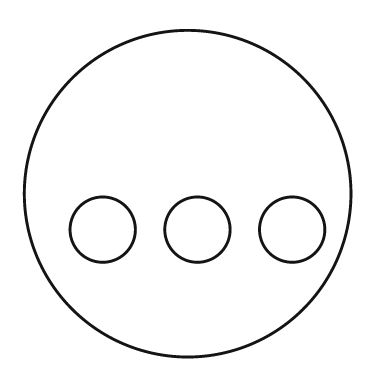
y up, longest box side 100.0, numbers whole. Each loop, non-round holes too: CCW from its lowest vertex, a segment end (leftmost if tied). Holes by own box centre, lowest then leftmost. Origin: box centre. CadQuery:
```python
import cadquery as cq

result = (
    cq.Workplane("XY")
    .moveTo(0.0, 0.0)
    .circle(50.0)
    .moveTo(-26.0, -11.0)
    .circle(10.0)
    .moveTo(3.0, -11.0)
    .circle(10.0)
    .moveTo(32.0, -11.0)
    .circle(10.0)
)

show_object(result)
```